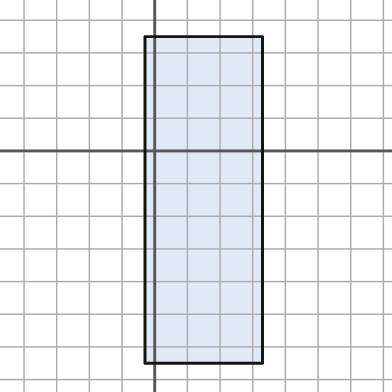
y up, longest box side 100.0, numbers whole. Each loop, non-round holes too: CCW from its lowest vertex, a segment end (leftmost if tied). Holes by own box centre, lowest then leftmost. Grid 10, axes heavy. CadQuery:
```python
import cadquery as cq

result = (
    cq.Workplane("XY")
    .moveTo(-3.0, -65.0)
    .lineTo(33.0, -65.0)
    .lineTo(33.0, 35.0)
    .lineTo(-3.0, 35.0)
    .close()
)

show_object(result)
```